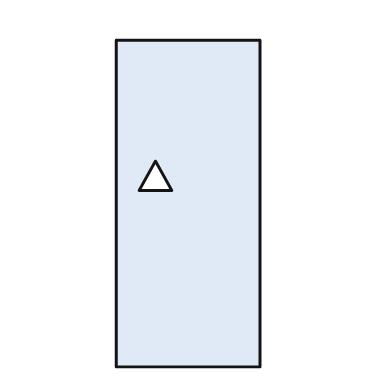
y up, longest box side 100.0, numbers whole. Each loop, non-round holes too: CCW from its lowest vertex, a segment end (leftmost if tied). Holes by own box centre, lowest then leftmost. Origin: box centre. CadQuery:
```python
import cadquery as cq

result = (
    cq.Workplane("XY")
    .moveTo(-22.0, -50.0)
    .lineTo(22.0, -50.0)
    .lineTo(22.0, 50.0)
    .lineTo(-22.0, 50.0)
    .close()
    .moveTo(-15.0, 4.0)
    .lineTo(-5.0, 4.0)
    .lineTo(-10.0, 13.0)
    .close()
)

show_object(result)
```